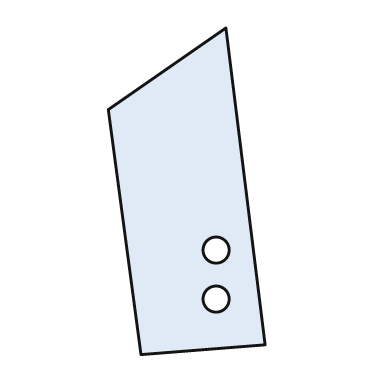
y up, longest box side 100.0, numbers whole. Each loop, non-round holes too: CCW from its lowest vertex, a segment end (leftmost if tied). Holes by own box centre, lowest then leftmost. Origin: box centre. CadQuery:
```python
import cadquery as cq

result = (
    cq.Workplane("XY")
    .moveTo(-14.0, -50.0)
    .lineTo(24.0, -47.0)
    .lineTo(12.0, 50.0)
    .lineTo(-24.0, 25.0)
    .close()
    .moveTo(9.0, -33.0)
    .circle(4.0)
    .moveTo(9.0, -18.0)
    .circle(4.0)
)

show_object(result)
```